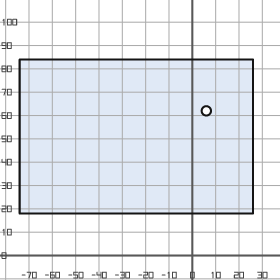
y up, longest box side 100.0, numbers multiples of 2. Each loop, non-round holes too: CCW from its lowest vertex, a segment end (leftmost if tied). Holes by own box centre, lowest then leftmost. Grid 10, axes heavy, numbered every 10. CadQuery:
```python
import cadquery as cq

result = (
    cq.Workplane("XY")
    .moveTo(-74.0, 18.0)
    .lineTo(26.0, 18.0)
    .lineTo(26.0, 84.0)
    .lineTo(-74.0, 84.0)
    .close()
    .moveTo(6.0, 62.0)
    .circle(2.0)
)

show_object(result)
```